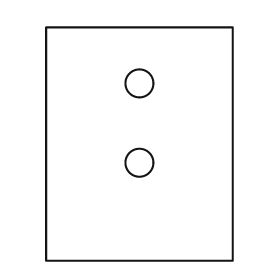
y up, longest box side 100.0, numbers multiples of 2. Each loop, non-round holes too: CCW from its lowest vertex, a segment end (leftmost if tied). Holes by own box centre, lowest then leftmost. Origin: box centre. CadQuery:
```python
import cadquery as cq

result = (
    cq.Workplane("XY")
    .moveTo(-40.0, -50.0)
    .lineTo(40.0, -50.0)
    .lineTo(40.0, 50.0)
    .lineTo(-40.0, 50.0)
    .close()
    .moveTo(0.0, -8.0)
    .circle(6.0)
    .moveTo(0.0, 26.0)
    .circle(6.0)
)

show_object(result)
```